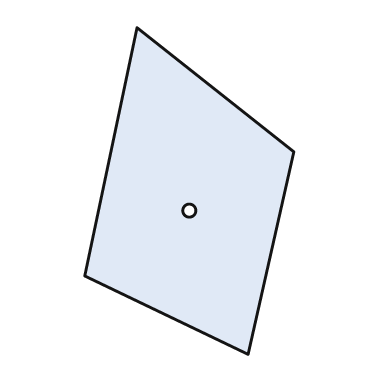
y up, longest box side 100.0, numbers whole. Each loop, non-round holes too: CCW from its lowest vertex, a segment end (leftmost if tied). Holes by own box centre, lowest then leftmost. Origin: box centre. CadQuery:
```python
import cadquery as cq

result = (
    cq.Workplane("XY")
    .moveTo(18.0, -50.0)
    .lineTo(32.0, 12.0)
    .lineTo(-16.0, 50.0)
    .lineTo(-32.0, -26.0)
    .close()
    .moveTo(0.0, -6.0)
    .circle(2.0)
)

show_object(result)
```